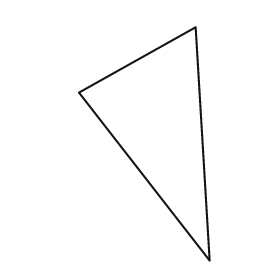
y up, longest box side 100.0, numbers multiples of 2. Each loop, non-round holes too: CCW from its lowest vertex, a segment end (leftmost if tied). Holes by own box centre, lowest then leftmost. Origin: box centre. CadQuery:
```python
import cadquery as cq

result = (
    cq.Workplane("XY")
    .moveTo(28.0, -50.0)
    .lineTo(22.0, 50.0)
    .lineTo(-28.0, 22.0)
    .close()
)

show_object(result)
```